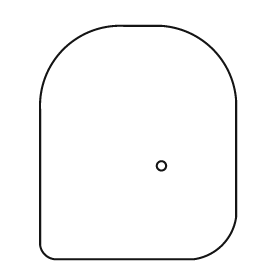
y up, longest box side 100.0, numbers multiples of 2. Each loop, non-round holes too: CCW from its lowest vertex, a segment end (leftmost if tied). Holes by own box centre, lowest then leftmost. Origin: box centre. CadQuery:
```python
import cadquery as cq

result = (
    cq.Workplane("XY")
    .moveTo(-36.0, -50.0)
    .lineTo(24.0, -50.0)
    .threePointArc((36.0, -44.0), (42.0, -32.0))
    .lineTo(42.0, 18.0)
    .threePointArc((32.0, 40.0), (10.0, 50.0))
    .lineTo(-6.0, 50.0)
    .threePointArc((-32.0, 40.0), (-42.0, 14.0))
    .lineTo(-42.0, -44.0)
    .threePointArc((-40.0, -48.0), (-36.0, -50.0))
    .close()
    .moveTo(10.0, -10.0)
    .circle(2.0)
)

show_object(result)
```